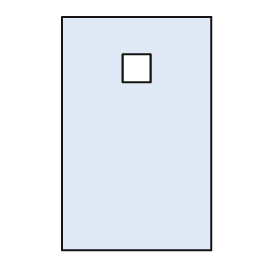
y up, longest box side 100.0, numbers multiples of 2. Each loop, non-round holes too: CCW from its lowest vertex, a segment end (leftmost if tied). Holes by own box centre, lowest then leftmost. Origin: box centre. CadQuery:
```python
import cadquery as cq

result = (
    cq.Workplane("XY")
    .moveTo(-32.0, -50.0)
    .lineTo(32.0, -50.0)
    .lineTo(32.0, 50.0)
    .lineTo(-32.0, 50.0)
    .close()
    .moveTo(-6.0, 22.0)
    .lineTo(6.0, 22.0)
    .lineTo(6.0, 34.0)
    .lineTo(-6.0, 34.0)
    .close()
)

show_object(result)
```